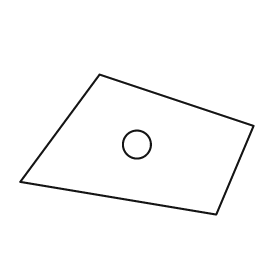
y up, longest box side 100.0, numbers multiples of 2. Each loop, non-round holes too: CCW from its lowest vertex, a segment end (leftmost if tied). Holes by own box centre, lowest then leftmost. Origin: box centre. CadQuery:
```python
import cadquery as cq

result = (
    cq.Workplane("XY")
    .moveTo(34.0, -30.0)
    .lineTo(50.0, 8.0)
    .lineTo(-16.0, 30.0)
    .lineTo(-50.0, -16.0)
    .close()
    .moveTo(0.0, 0.0)
    .circle(6.0)
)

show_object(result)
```